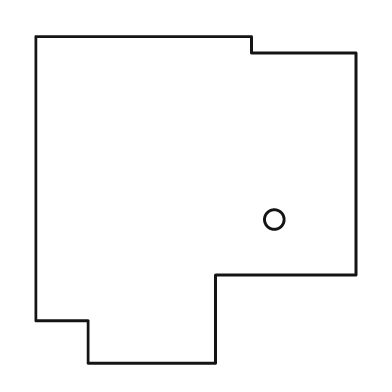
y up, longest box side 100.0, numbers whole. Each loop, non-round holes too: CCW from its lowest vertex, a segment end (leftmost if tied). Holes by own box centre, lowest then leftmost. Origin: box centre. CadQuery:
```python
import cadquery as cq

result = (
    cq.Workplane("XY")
    .moveTo(-33.0, -50.0)
    .lineTo(6.0, -50.0)
    .lineTo(6.0, -23.0)
    .lineTo(49.0, -23.0)
    .lineTo(49.0, 45.0)
    .lineTo(17.0, 45.0)
    .lineTo(17.0, 50.0)
    .lineTo(-49.0, 50.0)
    .lineTo(-49.0, -37.0)
    .lineTo(-33.0, -37.0)
    .close()
    .moveTo(24.0, -6.0)
    .circle(3.0)
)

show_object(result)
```